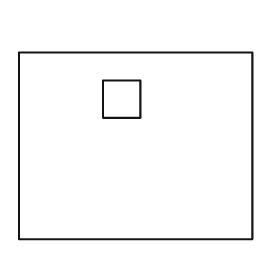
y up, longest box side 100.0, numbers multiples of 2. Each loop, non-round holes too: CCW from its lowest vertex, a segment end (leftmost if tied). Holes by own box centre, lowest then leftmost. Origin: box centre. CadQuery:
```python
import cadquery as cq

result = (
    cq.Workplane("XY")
    .moveTo(-50.0, -40.0)
    .lineTo(50.0, -40.0)
    .lineTo(50.0, 40.0)
    .lineTo(-50.0, 40.0)
    .close()
    .moveTo(-14.0, 12.0)
    .lineTo(2.0, 12.0)
    .lineTo(2.0, 28.0)
    .lineTo(-14.0, 28.0)
    .close()
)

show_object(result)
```